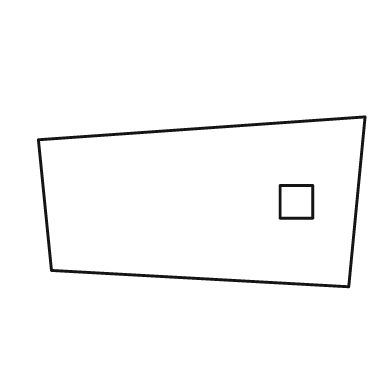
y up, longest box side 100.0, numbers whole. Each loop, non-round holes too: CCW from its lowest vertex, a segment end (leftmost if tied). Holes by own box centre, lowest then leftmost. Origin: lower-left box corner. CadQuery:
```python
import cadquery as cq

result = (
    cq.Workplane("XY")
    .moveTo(95.0, 0.0)
    .lineTo(100.0, 52.0)
    .lineTo(0.0, 45.0)
    .lineTo(4.0, 5.0)
    .close()
    .moveTo(74.0, 21.0)
    .lineTo(84.0, 21.0)
    .lineTo(84.0, 31.0)
    .lineTo(74.0, 31.0)
    .close()
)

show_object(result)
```